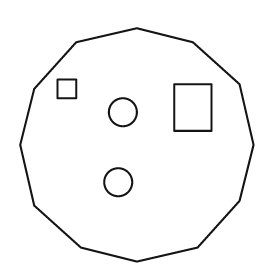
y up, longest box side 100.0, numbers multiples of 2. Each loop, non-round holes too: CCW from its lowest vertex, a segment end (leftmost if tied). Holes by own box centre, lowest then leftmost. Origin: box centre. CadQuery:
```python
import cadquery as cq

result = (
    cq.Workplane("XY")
    .moveTo(0.0, -50.0)
    .lineTo(26.0, -44.0)
    .lineTo(44.0, -24.0)
    .lineTo(50.0, 0.0)
    .lineTo(44.0, 26.0)
    .lineTo(24.0, 44.0)
    .lineTo(0.0, 50.0)
    .lineTo(-26.0, 44.0)
    .lineTo(-44.0, 24.0)
    .lineTo(-50.0, 0.0)
    .lineTo(-44.0, -26.0)
    .lineTo(-24.0, -44.0)
    .close()
    .moveTo(-8.0, -16.0)
    .circle(6.0)
    .moveTo(-6.0, 14.0)
    .circle(6.0)
    .moveTo(16.0, 6.0)
    .lineTo(32.0, 6.0)
    .lineTo(32.0, 26.0)
    .lineTo(16.0, 26.0)
    .close()
    .moveTo(-34.0, 20.0)
    .lineTo(-26.0, 20.0)
    .lineTo(-26.0, 28.0)
    .lineTo(-34.0, 28.0)
    .close()
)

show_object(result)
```